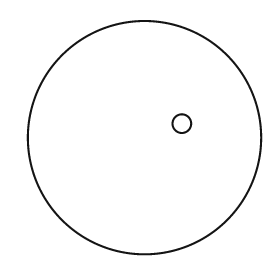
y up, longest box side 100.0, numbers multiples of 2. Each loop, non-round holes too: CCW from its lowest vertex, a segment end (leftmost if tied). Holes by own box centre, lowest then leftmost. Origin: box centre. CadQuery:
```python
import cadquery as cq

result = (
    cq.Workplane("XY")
    .moveTo(0.0, 0.0)
    .circle(50.0)
    .moveTo(16.0, 6.0)
    .circle(4.0)
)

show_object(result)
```